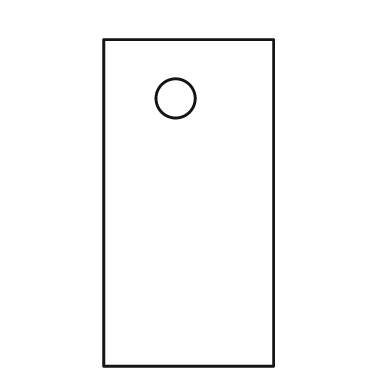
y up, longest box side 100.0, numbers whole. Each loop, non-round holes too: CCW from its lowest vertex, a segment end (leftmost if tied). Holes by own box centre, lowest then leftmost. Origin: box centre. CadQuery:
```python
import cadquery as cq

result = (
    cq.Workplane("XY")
    .moveTo(-26.0, -50.0)
    .lineTo(26.0, -50.0)
    .lineTo(26.0, 50.0)
    .lineTo(-26.0, 50.0)
    .close()
    .moveTo(-4.0, 32.0)
    .circle(6.0)
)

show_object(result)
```